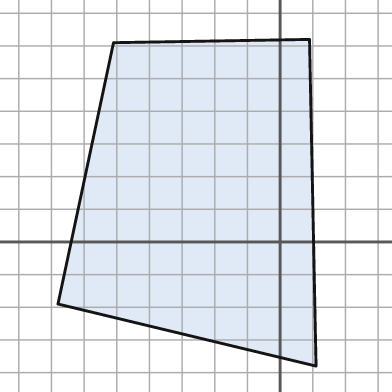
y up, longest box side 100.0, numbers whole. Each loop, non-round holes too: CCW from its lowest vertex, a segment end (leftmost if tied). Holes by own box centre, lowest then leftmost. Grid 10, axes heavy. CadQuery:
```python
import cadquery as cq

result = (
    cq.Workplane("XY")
    .moveTo(11.0, -38.0)
    .lineTo(9.0, 62.0)
    .lineTo(-51.0, 61.0)
    .lineTo(-68.0, -19.0)
    .close()
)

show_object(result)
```